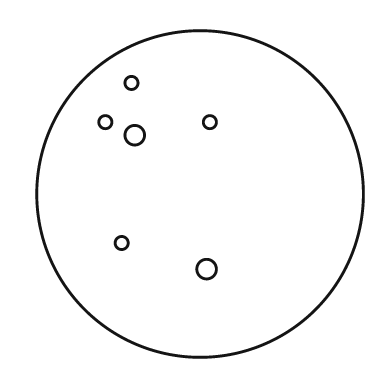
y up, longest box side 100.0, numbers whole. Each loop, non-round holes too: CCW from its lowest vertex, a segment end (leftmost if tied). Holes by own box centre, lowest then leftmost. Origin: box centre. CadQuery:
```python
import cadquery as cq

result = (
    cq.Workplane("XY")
    .moveTo(0.0, 0.0)
    .circle(50.0)
    .moveTo(2.0, -23.0)
    .circle(3.0)
    .moveTo(-24.0, -15.0)
    .circle(2.0)
    .moveTo(-20.0, 18.0)
    .circle(3.0)
    .moveTo(-29.0, 22.0)
    .circle(2.0)
    .moveTo(3.0, 22.0)
    .circle(2.0)
    .moveTo(-21.0, 34.0)
    .circle(2.0)
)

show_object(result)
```